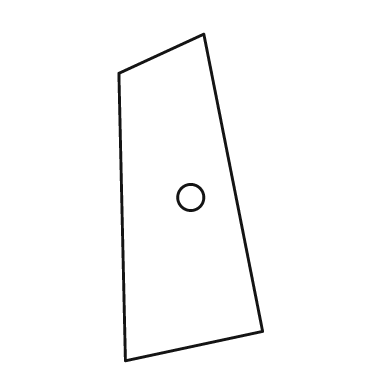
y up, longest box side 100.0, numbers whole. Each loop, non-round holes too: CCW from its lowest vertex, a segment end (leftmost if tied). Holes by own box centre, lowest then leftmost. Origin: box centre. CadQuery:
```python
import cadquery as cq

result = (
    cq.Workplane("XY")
    .moveTo(-20.0, -50.0)
    .lineTo(22.0, -41.0)
    .lineTo(4.0, 50.0)
    .lineTo(-22.0, 38.0)
    .close()
    .moveTo(0.0, 0.0)
    .circle(4.0)
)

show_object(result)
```